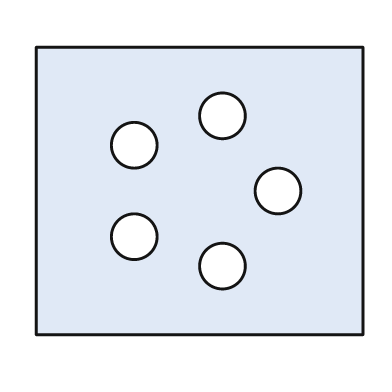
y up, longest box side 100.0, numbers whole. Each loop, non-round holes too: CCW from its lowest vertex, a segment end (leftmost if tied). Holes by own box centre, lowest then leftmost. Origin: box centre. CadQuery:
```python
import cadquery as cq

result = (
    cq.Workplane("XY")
    .moveTo(-50.0, -44.0)
    .lineTo(50.0, -44.0)
    .lineTo(50.0, 44.0)
    .lineTo(-50.0, 44.0)
    .close()
    .moveTo(7.0, -23.0)
    .circle(7.0)
    .moveTo(-20.0, -14.0)
    .circle(7.0)
    .moveTo(24.0, 0.0)
    .circle(7.0)
    .moveTo(-20.0, 14.0)
    .circle(7.0)
    .moveTo(7.0, 23.0)
    .circle(7.0)
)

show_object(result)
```